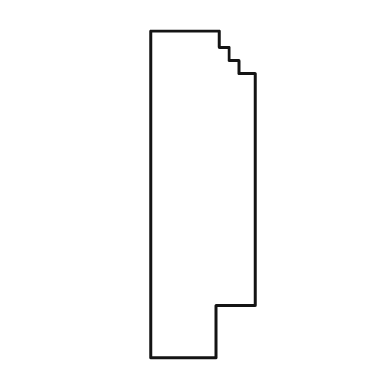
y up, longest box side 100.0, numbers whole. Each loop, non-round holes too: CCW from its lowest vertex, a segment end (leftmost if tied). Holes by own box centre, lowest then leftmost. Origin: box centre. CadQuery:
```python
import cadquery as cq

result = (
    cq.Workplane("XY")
    .moveTo(-16.0, -50.0)
    .lineTo(4.0, -50.0)
    .lineTo(4.0, -34.0)
    .lineTo(16.0, -34.0)
    .lineTo(16.0, 37.0)
    .lineTo(11.0, 37.0)
    .lineTo(11.0, 41.0)
    .lineTo(8.0, 41.0)
    .lineTo(8.0, 45.0)
    .lineTo(5.0, 45.0)
    .lineTo(5.0, 50.0)
    .lineTo(-16.0, 50.0)
    .close()
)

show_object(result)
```